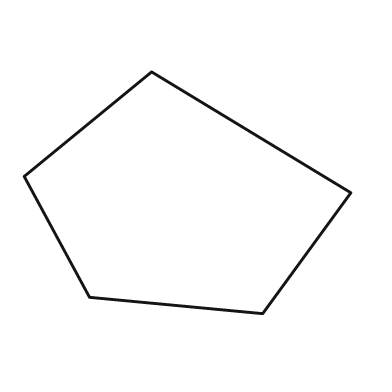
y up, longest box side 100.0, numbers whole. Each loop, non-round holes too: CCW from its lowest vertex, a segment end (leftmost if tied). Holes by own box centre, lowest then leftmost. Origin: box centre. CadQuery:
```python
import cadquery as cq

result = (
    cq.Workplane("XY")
    .moveTo(23.0, -37.0)
    .lineTo(50.0, 0.0)
    .lineTo(-11.0, 37.0)
    .lineTo(-50.0, 5.0)
    .lineTo(-30.0, -32.0)
    .close()
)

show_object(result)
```